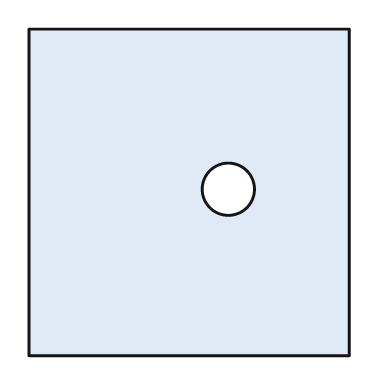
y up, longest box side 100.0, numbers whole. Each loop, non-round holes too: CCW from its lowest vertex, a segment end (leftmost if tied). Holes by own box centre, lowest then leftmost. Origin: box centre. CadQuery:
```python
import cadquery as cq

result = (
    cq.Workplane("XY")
    .moveTo(-49.0, -50.0)
    .lineTo(49.0, -50.0)
    .lineTo(49.0, 50.0)
    .lineTo(-49.0, 50.0)
    .close()
    .moveTo(12.0, 1.0)
    .circle(8.0)
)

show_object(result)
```